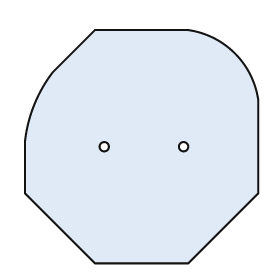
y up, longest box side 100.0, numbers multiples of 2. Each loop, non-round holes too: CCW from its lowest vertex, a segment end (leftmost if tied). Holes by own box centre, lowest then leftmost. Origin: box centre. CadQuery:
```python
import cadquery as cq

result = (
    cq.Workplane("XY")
    .moveTo(-20.0, -50.0)
    .lineTo(20.0, -50.0)
    .lineTo(50.0, -20.0)
    .lineTo(50.0, 20.0)
    .threePointArc((40.0, 40.0), (20.0, 50.0))
    .lineTo(-20.0, 50.0)
    .lineTo(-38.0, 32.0)
    .threePointArc((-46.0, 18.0), (-50.0, 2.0))
    .lineTo(-50.0, -20.0)
    .close()
    .moveTo(-16.0, 0.0)
    .circle(2.0)
    .moveTo(18.0, 0.0)
    .circle(2.0)
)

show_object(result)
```